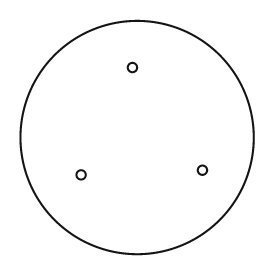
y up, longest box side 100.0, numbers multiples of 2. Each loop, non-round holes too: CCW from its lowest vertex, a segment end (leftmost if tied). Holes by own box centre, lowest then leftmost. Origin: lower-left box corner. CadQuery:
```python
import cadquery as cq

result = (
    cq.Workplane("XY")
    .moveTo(50.0, 50.0)
    .circle(50.0)
    .moveTo(26.0, 34.0)
    .circle(2.0)
    .moveTo(78.0, 36.0)
    .circle(2.0)
    .moveTo(48.0, 80.0)
    .circle(2.0)
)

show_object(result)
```